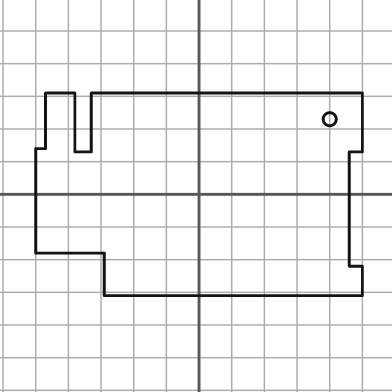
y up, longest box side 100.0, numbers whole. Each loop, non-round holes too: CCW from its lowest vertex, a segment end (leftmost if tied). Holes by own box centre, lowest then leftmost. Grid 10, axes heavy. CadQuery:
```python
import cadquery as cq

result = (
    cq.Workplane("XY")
    .moveTo(-29.0, -31.0)
    .lineTo(50.0, -31.0)
    .lineTo(50.0, -22.0)
    .lineTo(46.0, -22.0)
    .lineTo(46.0, 13.0)
    .lineTo(50.0, 13.0)
    .lineTo(50.0, 31.0)
    .lineTo(-33.0, 31.0)
    .lineTo(-33.0, 13.0)
    .lineTo(-38.0, 13.0)
    .lineTo(-38.0, 31.0)
    .lineTo(-47.0, 31.0)
    .lineTo(-47.0, 14.0)
    .lineTo(-50.0, 14.0)
    .lineTo(-50.0, -18.0)
    .lineTo(-29.0, -18.0)
    .close()
    .moveTo(40.0, 23.0)
    .circle(2.0)
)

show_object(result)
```